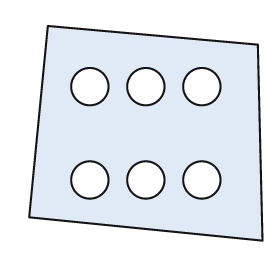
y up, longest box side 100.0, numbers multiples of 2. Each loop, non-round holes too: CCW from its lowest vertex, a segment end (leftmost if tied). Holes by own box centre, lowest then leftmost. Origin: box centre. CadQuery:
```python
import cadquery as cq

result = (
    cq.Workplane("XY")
    .moveTo(50.0, -46.0)
    .lineTo(48.0, 38.0)
    .lineTo(-42.0, 46.0)
    .lineTo(-50.0, -36.0)
    .close()
    .moveTo(-24.0, -20.0)
    .circle(8.0)
    .moveTo(0.0, -20.0)
    .circle(8.0)
    .moveTo(24.0, -20.0)
    .circle(8.0)
    .moveTo(-24.0, 20.0)
    .circle(8.0)
    .moveTo(0.0, 20.0)
    .circle(8.0)
    .moveTo(24.0, 20.0)
    .circle(8.0)
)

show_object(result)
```